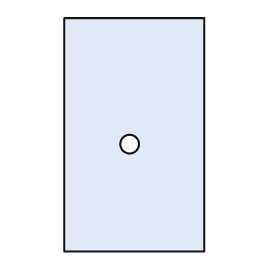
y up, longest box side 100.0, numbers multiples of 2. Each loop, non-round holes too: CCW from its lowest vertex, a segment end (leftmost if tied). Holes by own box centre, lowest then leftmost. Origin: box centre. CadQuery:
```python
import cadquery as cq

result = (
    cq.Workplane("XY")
    .moveTo(-30.0, -50.0)
    .lineTo(30.0, -50.0)
    .lineTo(30.0, 50.0)
    .lineTo(-30.0, 50.0)
    .close()
    .moveTo(-2.0, -4.0)
    .circle(4.0)
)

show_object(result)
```